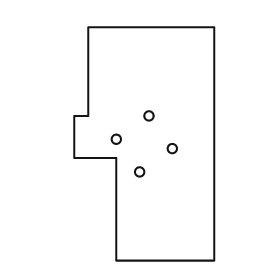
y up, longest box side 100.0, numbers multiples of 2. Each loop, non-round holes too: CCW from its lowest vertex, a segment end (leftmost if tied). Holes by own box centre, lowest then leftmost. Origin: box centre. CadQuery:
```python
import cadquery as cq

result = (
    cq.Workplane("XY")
    .moveTo(-12.0, -50.0)
    .lineTo(30.0, -50.0)
    .lineTo(30.0, 50.0)
    .lineTo(-24.0, 50.0)
    .lineTo(-24.0, 12.0)
    .lineTo(-30.0, 12.0)
    .lineTo(-30.0, -6.0)
    .lineTo(-12.0, -6.0)
    .close()
    .moveTo(-2.0, -12.0)
    .circle(2.0)
    .moveTo(12.0, -2.0)
    .circle(2.0)
    .moveTo(-12.0, 2.0)
    .circle(2.0)
    .moveTo(2.0, 12.0)
    .circle(2.0)
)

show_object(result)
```